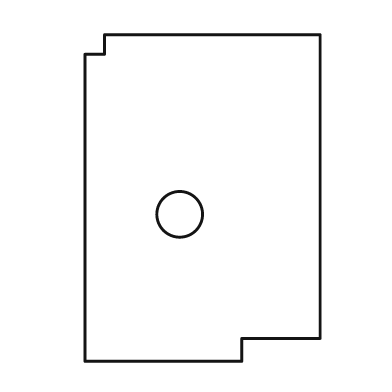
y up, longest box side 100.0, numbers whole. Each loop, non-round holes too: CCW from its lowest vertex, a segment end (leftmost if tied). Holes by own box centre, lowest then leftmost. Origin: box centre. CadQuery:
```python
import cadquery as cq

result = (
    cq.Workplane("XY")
    .moveTo(-36.0, -50.0)
    .lineTo(12.0, -50.0)
    .lineTo(12.0, -43.0)
    .lineTo(36.0, -43.0)
    .lineTo(36.0, 50.0)
    .lineTo(-30.0, 50.0)
    .lineTo(-30.0, 44.0)
    .lineTo(-36.0, 44.0)
    .close()
    .moveTo(-7.0, -5.0)
    .circle(7.0)
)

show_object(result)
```